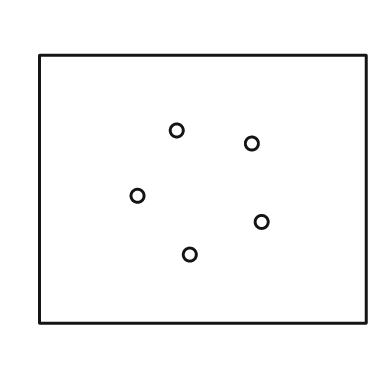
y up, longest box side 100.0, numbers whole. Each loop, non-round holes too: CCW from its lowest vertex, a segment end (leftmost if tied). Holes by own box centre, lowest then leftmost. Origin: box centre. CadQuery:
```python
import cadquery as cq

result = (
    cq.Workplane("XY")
    .moveTo(-50.0, -41.0)
    .lineTo(50.0, -41.0)
    .lineTo(50.0, 41.0)
    .lineTo(-50.0, 41.0)
    .close()
    .moveTo(-4.0, -20.0)
    .circle(2.0)
    .moveTo(18.0, -10.0)
    .circle(2.0)
    .moveTo(-20.0, -2.0)
    .circle(2.0)
    .moveTo(15.0, 14.0)
    .circle(2.0)
    .moveTo(-8.0, 18.0)
    .circle(2.0)
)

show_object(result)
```